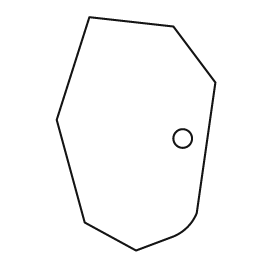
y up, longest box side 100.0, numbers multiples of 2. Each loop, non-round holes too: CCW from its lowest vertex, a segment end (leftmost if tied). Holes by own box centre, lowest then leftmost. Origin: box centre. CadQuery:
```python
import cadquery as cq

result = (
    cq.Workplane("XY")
    .moveTo(0.0, -50.0)
    .lineTo(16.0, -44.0)
    .threePointArc((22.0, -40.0), (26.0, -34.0))
    .lineTo(34.0, 22.0)
    .lineTo(16.0, 46.0)
    .lineTo(-20.0, 50.0)
    .lineTo(-34.0, 6.0)
    .lineTo(-22.0, -38.0)
    .close()
    .moveTo(20.0, -2.0)
    .circle(4.0)
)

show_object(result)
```